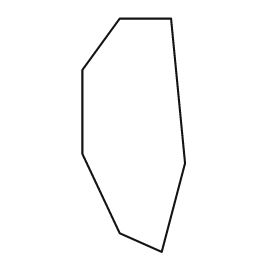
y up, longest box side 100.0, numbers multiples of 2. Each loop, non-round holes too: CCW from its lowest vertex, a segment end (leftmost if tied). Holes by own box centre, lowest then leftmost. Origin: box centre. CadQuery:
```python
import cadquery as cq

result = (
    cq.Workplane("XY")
    .moveTo(12.0, -50.0)
    .lineTo(22.0, -12.0)
    .lineTo(16.0, 50.0)
    .lineTo(-6.0, 50.0)
    .lineTo(-22.0, 28.0)
    .lineTo(-22.0, -8.0)
    .lineTo(-6.0, -42.0)
    .close()
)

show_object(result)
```